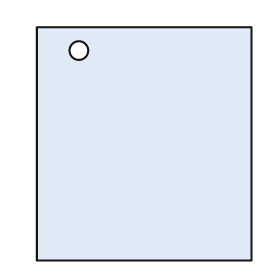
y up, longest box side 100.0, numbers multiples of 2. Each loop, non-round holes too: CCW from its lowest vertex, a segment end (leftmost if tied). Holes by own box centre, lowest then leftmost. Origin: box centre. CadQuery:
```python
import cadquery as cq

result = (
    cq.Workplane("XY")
    .moveTo(-46.0, -50.0)
    .lineTo(46.0, -50.0)
    .lineTo(46.0, 50.0)
    .lineTo(-46.0, 50.0)
    .close()
    .moveTo(-28.0, 40.0)
    .circle(4.0)
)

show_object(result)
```